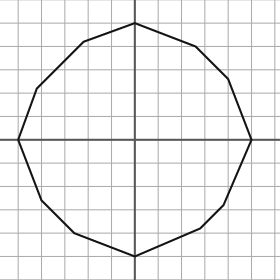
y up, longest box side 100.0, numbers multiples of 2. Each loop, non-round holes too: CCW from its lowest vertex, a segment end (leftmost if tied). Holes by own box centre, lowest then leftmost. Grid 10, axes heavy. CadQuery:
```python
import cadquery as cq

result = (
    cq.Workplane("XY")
    .moveTo(0.0, -50.0)
    .lineTo(28.0, -38.0)
    .lineTo(38.0, -28.0)
    .lineTo(50.0, 0.0)
    .lineTo(40.0, 26.0)
    .lineTo(26.0, 40.0)
    .lineTo(0.0, 50.0)
    .lineTo(-22.0, 42.0)
    .lineTo(-42.0, 22.0)
    .lineTo(-50.0, 0.0)
    .lineTo(-40.0, -26.0)
    .lineTo(-26.0, -40.0)
    .close()
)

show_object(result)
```